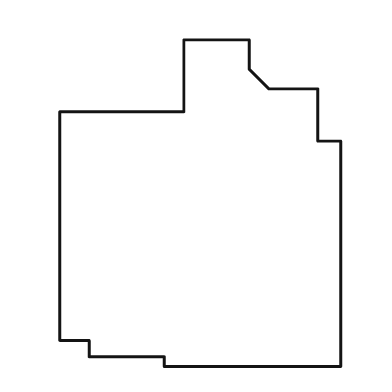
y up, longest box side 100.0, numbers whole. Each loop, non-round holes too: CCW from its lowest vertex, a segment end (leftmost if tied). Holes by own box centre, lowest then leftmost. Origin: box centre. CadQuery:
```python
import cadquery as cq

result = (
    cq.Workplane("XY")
    .moveTo(-11.0, -50.0)
    .lineTo(43.0, -50.0)
    .lineTo(43.0, 19.0)
    .lineTo(36.0, 19.0)
    .lineTo(36.0, 35.0)
    .lineTo(21.0, 35.0)
    .lineTo(15.0, 41.0)
    .lineTo(15.0, 50.0)
    .lineTo(-5.0, 50.0)
    .lineTo(-5.0, 28.0)
    .lineTo(-43.0, 28.0)
    .lineTo(-43.0, -42.0)
    .lineTo(-34.0, -42.0)
    .lineTo(-34.0, -47.0)
    .lineTo(-11.0, -47.0)
    .close()
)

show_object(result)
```